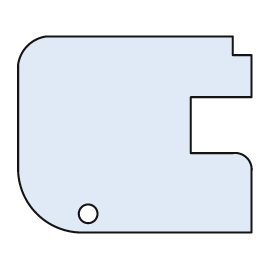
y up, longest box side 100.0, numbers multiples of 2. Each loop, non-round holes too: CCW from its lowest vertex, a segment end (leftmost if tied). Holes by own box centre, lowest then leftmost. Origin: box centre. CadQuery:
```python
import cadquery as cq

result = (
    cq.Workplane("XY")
    .moveTo(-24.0, -42.0)
    .lineTo(50.0, -42.0)
    .lineTo(50.0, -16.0)
    .threePointArc((48.0, -10.0), (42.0, -8.0))
    .lineTo(24.0, -8.0)
    .lineTo(24.0, 16.0)
    .lineTo(50.0, 16.0)
    .lineTo(50.0, 34.0)
    .lineTo(42.0, 34.0)
    .lineTo(42.0, 42.0)
    .lineTo(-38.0, 42.0)
    .threePointArc((-46.0, 38.0), (-50.0, 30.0))
    .lineTo(-50.0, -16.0)
    .threePointArc((-42.0, -34.0), (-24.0, -42.0))
    .close()
    .moveTo(-20.0, -34.0)
    .circle(4.0)
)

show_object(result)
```